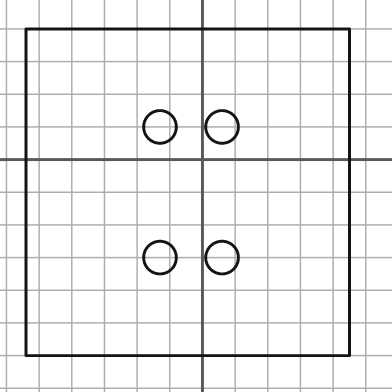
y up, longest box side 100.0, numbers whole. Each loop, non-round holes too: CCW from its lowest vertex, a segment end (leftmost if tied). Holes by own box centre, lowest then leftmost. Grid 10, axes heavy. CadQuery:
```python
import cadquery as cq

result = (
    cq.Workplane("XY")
    .moveTo(-54.0, -60.0)
    .lineTo(45.0, -60.0)
    .lineTo(45.0, 40.0)
    .lineTo(-54.0, 40.0)
    .close()
    .moveTo(-13.0, -30.0)
    .circle(5.0)
    .moveTo(6.0, -30.0)
    .circle(5.0)
    .moveTo(-13.0, 10.0)
    .circle(5.0)
    .moveTo(6.0, 10.0)
    .circle(5.0)
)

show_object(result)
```